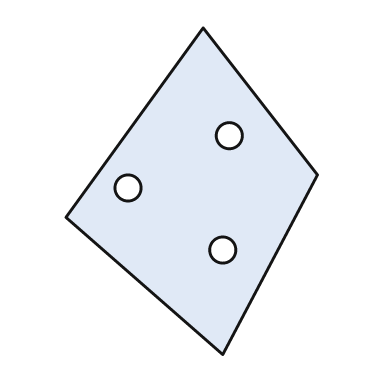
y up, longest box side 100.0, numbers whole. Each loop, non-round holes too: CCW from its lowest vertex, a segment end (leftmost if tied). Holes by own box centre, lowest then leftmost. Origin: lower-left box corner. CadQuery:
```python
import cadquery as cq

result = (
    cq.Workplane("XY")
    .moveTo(48.0, 0.0)
    .lineTo(77.0, 55.0)
    .lineTo(42.0, 100.0)
    .lineTo(0.0, 42.0)
    .close()
    .moveTo(48.0, 32.0)
    .circle(4.0)
    .moveTo(19.0, 51.0)
    .circle(4.0)
    .moveTo(50.0, 67.0)
    .circle(4.0)
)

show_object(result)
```